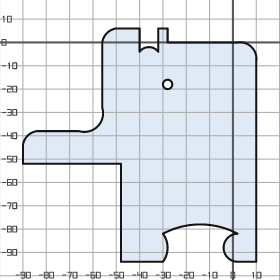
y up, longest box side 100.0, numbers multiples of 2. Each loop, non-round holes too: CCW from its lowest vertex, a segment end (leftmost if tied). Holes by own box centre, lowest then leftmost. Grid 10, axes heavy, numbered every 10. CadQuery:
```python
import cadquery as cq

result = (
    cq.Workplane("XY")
    .moveTo(-48.0, -94.0)
    .lineTo(-30.0, -94.0)
    .threePointArc((-28.0, -88.0), (-30.0, -82.0))
    .threePointArc((-14.0, -78.0), (2.0, -82.0))
    .threePointArc((-4.0, -88.0), (2.0, -94.0))
    .lineTo(10.0, -94.0)
    .lineTo(10.0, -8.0)
    .threePointArc((8.0, -2.0), (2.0, 0.0))
    .lineTo(-28.0, 0.0)
    .lineTo(-28.0, 6.0)
    .lineTo(-32.0, 6.0)
    .lineTo(-32.0, -4.0)
    .threePointArc((-36.0, -2.0), (-40.0, -4.0))
    .lineTo(-40.0, 6.0)
    .lineTo(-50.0, 6.0)
    .threePointArc((-54.0, 4.0), (-56.0, 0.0))
    .lineTo(-56.0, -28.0)
    .threePointArc((-58.0, -36.0), (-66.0, -38.0))
    .lineTo(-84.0, -38.0)
    .threePointArc((-88.0, -40.0), (-90.0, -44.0))
    .lineTo(-90.0, -52.0)
    .lineTo(-48.0, -52.0)
    .close()
    .moveTo(-28.0, -18.0)
    .circle(2.0)
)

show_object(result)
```